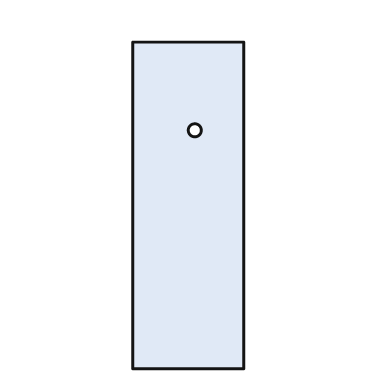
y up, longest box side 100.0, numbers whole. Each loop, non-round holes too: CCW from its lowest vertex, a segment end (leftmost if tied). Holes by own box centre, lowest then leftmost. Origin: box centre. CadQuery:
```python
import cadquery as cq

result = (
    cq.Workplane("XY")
    .moveTo(-17.0, -50.0)
    .lineTo(17.0, -50.0)
    .lineTo(17.0, 50.0)
    .lineTo(-17.0, 50.0)
    .close()
    .moveTo(2.0, 23.0)
    .circle(2.0)
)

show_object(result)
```